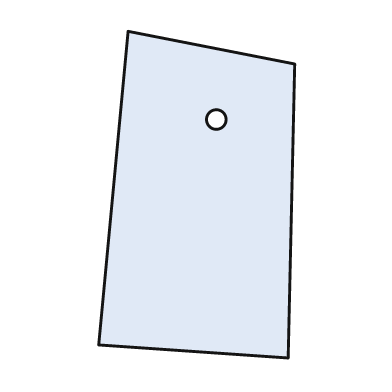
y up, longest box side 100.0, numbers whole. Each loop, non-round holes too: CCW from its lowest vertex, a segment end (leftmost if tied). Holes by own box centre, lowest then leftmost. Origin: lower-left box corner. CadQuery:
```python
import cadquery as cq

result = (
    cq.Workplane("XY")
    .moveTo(58.0, 0.0)
    .lineTo(60.0, 90.0)
    .lineTo(9.0, 100.0)
    .lineTo(0.0, 4.0)
    .close()
    .moveTo(36.0, 73.0)
    .circle(3.0)
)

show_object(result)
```